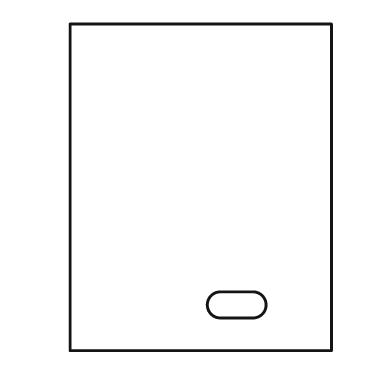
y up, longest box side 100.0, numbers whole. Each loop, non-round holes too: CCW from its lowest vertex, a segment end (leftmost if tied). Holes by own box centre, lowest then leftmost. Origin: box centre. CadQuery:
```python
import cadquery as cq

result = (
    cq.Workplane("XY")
    .moveTo(-40.0, -50.0)
    .lineTo(40.0, -50.0)
    .lineTo(40.0, 50.0)
    .lineTo(-40.0, 50.0)
    .close()
    .moveTo(6.0, -40.0)
    .lineTo(16.0, -40.0)
    .threePointArc((20.0, -36.0), (16.0, -32.0))
    .lineTo(6.0, -32.0)
    .threePointArc((2.0, -36.0), (6.0, -40.0))
    .close()
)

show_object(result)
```